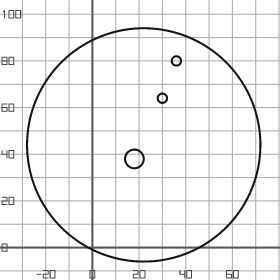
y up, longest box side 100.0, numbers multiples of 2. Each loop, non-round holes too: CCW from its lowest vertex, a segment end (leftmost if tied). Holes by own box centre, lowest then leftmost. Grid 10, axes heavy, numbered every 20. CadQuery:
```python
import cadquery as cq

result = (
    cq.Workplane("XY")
    .moveTo(22.0, 44.0)
    .circle(50.0)
    .moveTo(18.0, 38.0)
    .circle(4.0)
    .moveTo(30.0, 64.0)
    .circle(2.0)
    .moveTo(36.0, 80.0)
    .circle(2.0)
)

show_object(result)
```